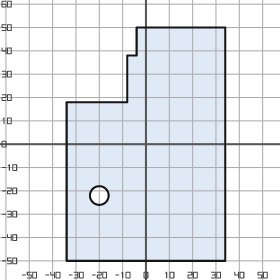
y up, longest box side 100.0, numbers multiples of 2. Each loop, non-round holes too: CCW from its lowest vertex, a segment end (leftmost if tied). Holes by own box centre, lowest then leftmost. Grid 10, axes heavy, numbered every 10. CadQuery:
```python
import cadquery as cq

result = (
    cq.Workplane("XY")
    .moveTo(-34.0, -50.0)
    .lineTo(34.0, -50.0)
    .lineTo(34.0, 50.0)
    .lineTo(-4.0, 50.0)
    .lineTo(-4.0, 38.0)
    .lineTo(-8.0, 38.0)
    .lineTo(-8.0, 18.0)
    .lineTo(-34.0, 18.0)
    .close()
    .moveTo(-20.0, -22.0)
    .circle(4.0)
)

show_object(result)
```